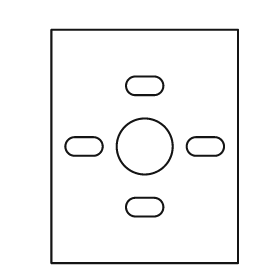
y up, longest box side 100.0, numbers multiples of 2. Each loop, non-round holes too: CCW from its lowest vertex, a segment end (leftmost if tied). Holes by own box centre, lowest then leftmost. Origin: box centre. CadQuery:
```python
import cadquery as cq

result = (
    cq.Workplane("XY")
    .moveTo(-40.0, -50.0)
    .lineTo(40.0, -50.0)
    .lineTo(40.0, 50.0)
    .lineTo(-40.0, 50.0)
    .close()
    .moveTo(-4.0, -30.0)
    .lineTo(4.0, -30.0)
    .threePointArc((8.0, -26.0), (4.0, -22.0))
    .lineTo(-4.0, -22.0)
    .threePointArc((-8.0, -26.0), (-4.0, -30.0))
    .close()
    .moveTo(-30.0, -4.0)
    .lineTo(-22.0, -4.0)
    .threePointArc((-18.0, 0.0), (-22.0, 4.0))
    .lineTo(-30.0, 4.0)
    .threePointArc((-34.0, 0.0), (-30.0, -4.0))
    .close()
    .moveTo(0.0, 0.0)
    .circle(12.0)
    .moveTo(22.0, -4.0)
    .lineTo(30.0, -4.0)
    .threePointArc((34.0, 0.0), (30.0, 4.0))
    .lineTo(22.0, 4.0)
    .threePointArc((18.0, 0.0), (22.0, -4.0))
    .close()
    .moveTo(-4.0, 22.0)
    .lineTo(4.0, 22.0)
    .threePointArc((8.0, 26.0), (4.0, 30.0))
    .lineTo(-4.0, 30.0)
    .threePointArc((-8.0, 26.0), (-4.0, 22.0))
    .close()
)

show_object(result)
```